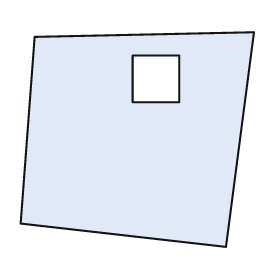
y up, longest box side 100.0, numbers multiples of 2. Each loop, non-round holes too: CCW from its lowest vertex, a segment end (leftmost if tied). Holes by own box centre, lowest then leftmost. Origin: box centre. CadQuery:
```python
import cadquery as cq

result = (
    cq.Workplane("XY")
    .moveTo(38.0, -46.0)
    .lineTo(50.0, 46.0)
    .lineTo(-44.0, 44.0)
    .lineTo(-50.0, -36.0)
    .close()
    .moveTo(-2.0, 16.0)
    .lineTo(18.0, 16.0)
    .lineTo(18.0, 36.0)
    .lineTo(-2.0, 36.0)
    .close()
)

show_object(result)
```